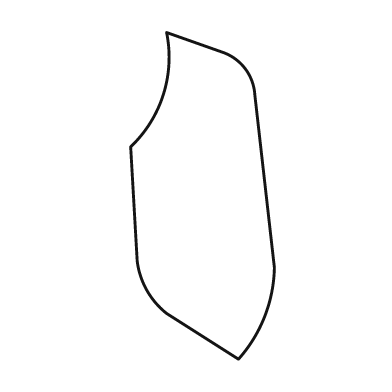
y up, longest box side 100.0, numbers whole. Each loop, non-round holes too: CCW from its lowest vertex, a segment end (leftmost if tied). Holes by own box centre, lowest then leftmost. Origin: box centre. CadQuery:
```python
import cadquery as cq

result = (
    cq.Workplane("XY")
    .moveTo(11.0, -50.0)
    .threePointArc((19.0, -37.0), (22.0, -22.0))
    .lineTo(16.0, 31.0)
    .threePointArc((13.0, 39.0), (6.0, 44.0))
    .lineTo(-11.0, 50.0)
    .threePointArc((-12.0, 31.0), (-22.0, 15.0))
    .lineTo(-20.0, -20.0)
    .threePointArc((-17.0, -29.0), (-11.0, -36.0))
    .close()
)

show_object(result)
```